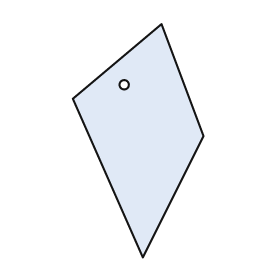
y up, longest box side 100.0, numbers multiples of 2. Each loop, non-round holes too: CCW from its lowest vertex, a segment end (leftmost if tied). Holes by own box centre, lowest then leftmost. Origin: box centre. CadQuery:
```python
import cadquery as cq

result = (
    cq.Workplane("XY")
    .moveTo(2.0, -50.0)
    .lineTo(28.0, 2.0)
    .lineTo(10.0, 50.0)
    .lineTo(-28.0, 18.0)
    .close()
    .moveTo(-6.0, 24.0)
    .circle(2.0)
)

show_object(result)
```